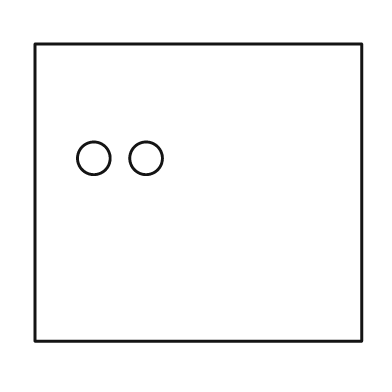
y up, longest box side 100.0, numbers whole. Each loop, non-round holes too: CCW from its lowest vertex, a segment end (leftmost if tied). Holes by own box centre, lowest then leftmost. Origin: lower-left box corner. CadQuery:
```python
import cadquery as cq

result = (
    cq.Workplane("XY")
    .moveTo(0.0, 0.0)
    .lineTo(100.0, 0.0)
    .lineTo(100.0, 91.0)
    .lineTo(0.0, 91.0)
    .close()
    .moveTo(18.0, 56.0)
    .circle(5.0)
    .moveTo(34.0, 56.0)
    .circle(5.0)
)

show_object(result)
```